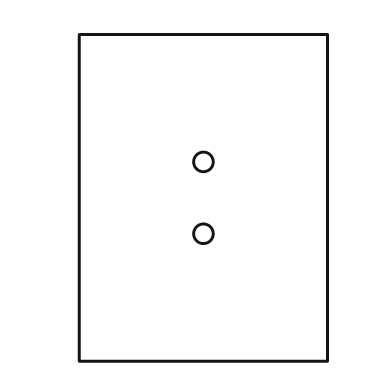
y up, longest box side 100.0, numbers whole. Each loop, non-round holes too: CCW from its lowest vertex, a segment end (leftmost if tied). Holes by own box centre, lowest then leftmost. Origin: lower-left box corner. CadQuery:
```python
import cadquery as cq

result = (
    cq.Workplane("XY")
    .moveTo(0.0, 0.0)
    .lineTo(76.0, 0.0)
    .lineTo(76.0, 100.0)
    .lineTo(0.0, 100.0)
    .close()
    .moveTo(38.0, 39.0)
    .circle(3.0)
    .moveTo(38.0, 61.0)
    .circle(3.0)
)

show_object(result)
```